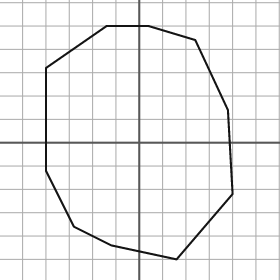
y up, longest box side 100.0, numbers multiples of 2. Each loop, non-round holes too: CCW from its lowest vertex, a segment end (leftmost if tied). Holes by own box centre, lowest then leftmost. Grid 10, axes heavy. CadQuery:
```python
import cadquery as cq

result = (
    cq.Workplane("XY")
    .moveTo(16.0, -50.0)
    .lineTo(40.0, -22.0)
    .lineTo(38.0, 14.0)
    .lineTo(24.0, 44.0)
    .lineTo(4.0, 50.0)
    .lineTo(-14.0, 50.0)
    .lineTo(-40.0, 32.0)
    .lineTo(-40.0, -12.0)
    .lineTo(-28.0, -36.0)
    .lineTo(-12.0, -44.0)
    .close()
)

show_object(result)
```